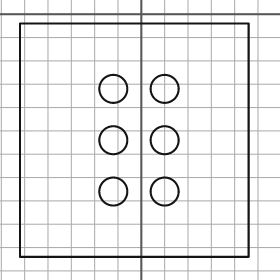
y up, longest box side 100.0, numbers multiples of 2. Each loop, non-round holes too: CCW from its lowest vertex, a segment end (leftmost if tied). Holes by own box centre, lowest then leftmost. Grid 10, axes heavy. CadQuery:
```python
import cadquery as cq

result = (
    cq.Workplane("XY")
    .moveTo(-52.0, -104.0)
    .lineTo(46.0, -104.0)
    .lineTo(46.0, -4.0)
    .lineTo(-52.0, -4.0)
    .close()
    .moveTo(-12.0, -76.0)
    .circle(6.0)
    .moveTo(10.0, -76.0)
    .circle(6.0)
    .moveTo(-12.0, -54.0)
    .circle(6.0)
    .moveTo(10.0, -54.0)
    .circle(6.0)
    .moveTo(-12.0, -32.0)
    .circle(6.0)
    .moveTo(10.0, -32.0)
    .circle(6.0)
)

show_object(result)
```